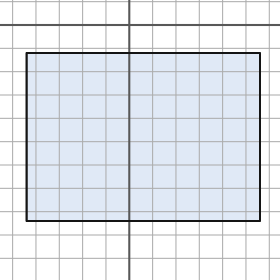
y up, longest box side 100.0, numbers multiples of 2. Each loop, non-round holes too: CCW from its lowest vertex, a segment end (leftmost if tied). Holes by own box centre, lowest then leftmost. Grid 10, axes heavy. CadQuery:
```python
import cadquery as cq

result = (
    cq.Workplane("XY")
    .moveTo(-44.0, -84.0)
    .lineTo(56.0, -84.0)
    .lineTo(56.0, -12.0)
    .lineTo(-44.0, -12.0)
    .close()
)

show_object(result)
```